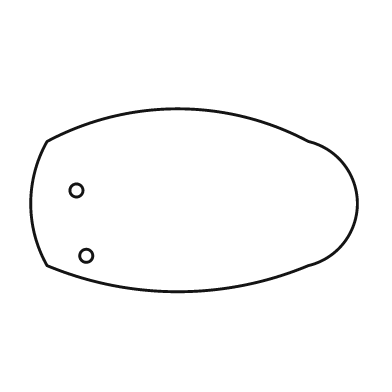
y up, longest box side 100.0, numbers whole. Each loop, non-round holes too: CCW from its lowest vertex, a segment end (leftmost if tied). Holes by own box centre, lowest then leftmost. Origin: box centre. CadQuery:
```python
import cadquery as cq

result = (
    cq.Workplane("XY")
    .moveTo(-45.0, -20.0)
    .threePointArc((-5.0, -28.0), (35.0, -20.0))
    .threePointArc((50.0, -1.0), (35.0, 18.0))
    .threePointArc((-5.0, 28.0), (-45.0, 18.0))
    .threePointArc((-50.0, -1.0), (-45.0, -20.0))
    .close()
    .moveTo(-33.0, -17.0)
    .circle(2.0)
    .moveTo(-36.0, 3.0)
    .circle(2.0)
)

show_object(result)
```